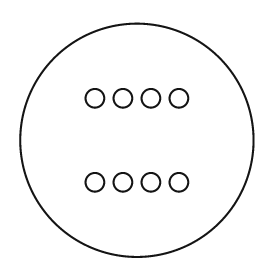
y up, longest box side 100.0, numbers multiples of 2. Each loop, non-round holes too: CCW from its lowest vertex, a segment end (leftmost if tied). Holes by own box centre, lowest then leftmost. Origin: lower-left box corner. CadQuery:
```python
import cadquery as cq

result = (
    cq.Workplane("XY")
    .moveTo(50.0, 50.0)
    .circle(50.0)
    .moveTo(32.0, 32.0)
    .circle(4.0)
    .moveTo(44.0, 32.0)
    .circle(4.0)
    .moveTo(56.0, 32.0)
    .circle(4.0)
    .moveTo(68.0, 32.0)
    .circle(4.0)
    .moveTo(32.0, 68.0)
    .circle(4.0)
    .moveTo(44.0, 68.0)
    .circle(4.0)
    .moveTo(56.0, 68.0)
    .circle(4.0)
    .moveTo(68.0, 68.0)
    .circle(4.0)
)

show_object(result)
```